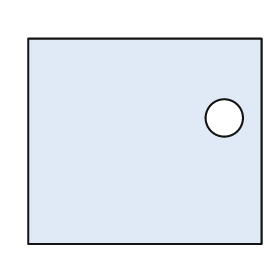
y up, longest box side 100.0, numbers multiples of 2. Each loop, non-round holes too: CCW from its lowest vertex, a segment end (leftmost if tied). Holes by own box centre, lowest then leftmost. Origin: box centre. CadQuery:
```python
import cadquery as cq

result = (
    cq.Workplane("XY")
    .moveTo(-50.0, -44.0)
    .lineTo(50.0, -44.0)
    .lineTo(50.0, 44.0)
    .lineTo(-50.0, 44.0)
    .close()
    .moveTo(34.0, 10.0)
    .circle(8.0)
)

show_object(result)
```